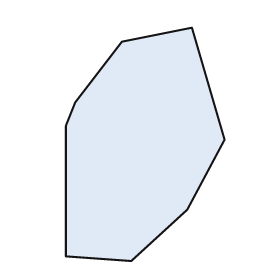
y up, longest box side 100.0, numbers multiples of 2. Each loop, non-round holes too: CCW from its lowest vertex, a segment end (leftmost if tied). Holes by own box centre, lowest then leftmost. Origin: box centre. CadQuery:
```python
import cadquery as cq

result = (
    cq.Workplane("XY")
    .moveTo(-6.0, -50.0)
    .lineTo(18.0, -28.0)
    .lineTo(34.0, 2.0)
    .lineTo(20.0, 50.0)
    .lineTo(-10.0, 44.0)
    .lineTo(-30.0, 18.0)
    .lineTo(-34.0, 8.0)
    .lineTo(-34.0, -48.0)
    .close()
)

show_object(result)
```